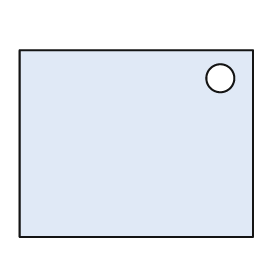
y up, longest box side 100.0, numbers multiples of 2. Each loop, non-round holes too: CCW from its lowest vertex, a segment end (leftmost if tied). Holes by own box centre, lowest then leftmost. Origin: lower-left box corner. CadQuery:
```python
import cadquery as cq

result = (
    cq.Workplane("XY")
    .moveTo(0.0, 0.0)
    .lineTo(100.0, 0.0)
    .lineTo(100.0, 80.0)
    .lineTo(0.0, 80.0)
    .close()
    .moveTo(86.0, 68.0)
    .circle(6.0)
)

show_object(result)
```